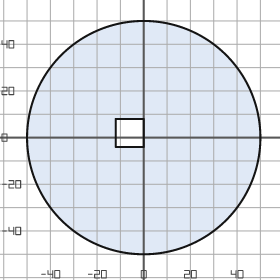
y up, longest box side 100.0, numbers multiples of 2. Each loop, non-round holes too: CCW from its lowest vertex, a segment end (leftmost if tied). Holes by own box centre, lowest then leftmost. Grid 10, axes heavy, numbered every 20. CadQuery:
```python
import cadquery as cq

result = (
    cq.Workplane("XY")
    .moveTo(0.0, 0.0)
    .circle(50.0)
    .moveTo(-12.0, -4.0)
    .lineTo(0.0, -4.0)
    .lineTo(0.0, 8.0)
    .lineTo(-12.0, 8.0)
    .close()
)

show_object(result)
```